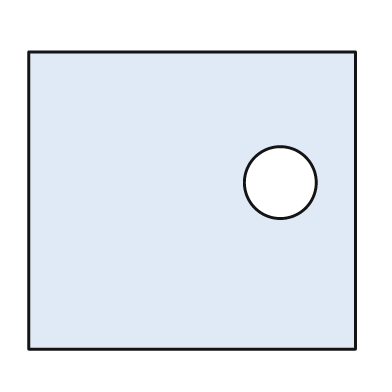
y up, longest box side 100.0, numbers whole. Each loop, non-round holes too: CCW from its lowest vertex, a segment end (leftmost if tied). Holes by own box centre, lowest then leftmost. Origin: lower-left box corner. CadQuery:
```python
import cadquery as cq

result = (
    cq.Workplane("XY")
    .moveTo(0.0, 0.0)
    .lineTo(100.0, 0.0)
    .lineTo(100.0, 91.0)
    .lineTo(0.0, 91.0)
    .close()
    .moveTo(77.0, 51.0)
    .circle(11.0)
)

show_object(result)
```